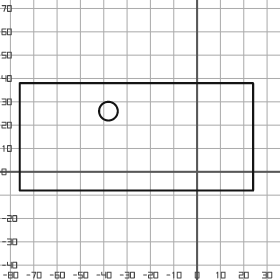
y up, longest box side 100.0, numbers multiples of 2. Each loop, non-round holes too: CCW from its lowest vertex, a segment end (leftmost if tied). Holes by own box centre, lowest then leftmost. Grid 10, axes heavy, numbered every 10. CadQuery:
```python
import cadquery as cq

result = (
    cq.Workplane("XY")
    .moveTo(-76.0, -8.0)
    .lineTo(24.0, -8.0)
    .lineTo(24.0, 38.0)
    .lineTo(-76.0, 38.0)
    .close()
    .moveTo(-38.0, 26.0)
    .circle(4.0)
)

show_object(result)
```